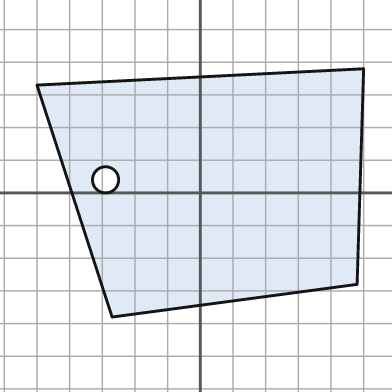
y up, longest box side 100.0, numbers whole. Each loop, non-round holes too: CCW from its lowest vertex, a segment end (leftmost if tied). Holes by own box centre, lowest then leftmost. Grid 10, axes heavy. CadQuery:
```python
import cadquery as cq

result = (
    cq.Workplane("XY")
    .moveTo(-27.0, -38.0)
    .lineTo(48.0, -28.0)
    .lineTo(50.0, 38.0)
    .lineTo(-50.0, 33.0)
    .close()
    .moveTo(-29.0, 4.0)
    .circle(4.0)
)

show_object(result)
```